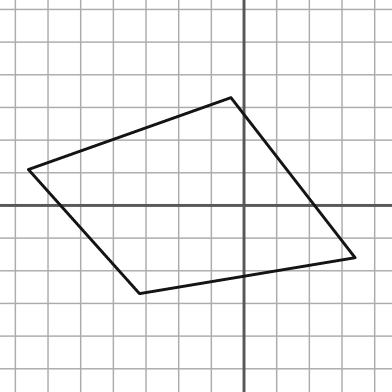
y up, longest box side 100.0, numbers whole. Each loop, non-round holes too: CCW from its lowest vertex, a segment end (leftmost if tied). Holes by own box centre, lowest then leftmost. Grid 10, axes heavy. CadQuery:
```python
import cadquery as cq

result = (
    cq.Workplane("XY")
    .moveTo(-32.0, -27.0)
    .lineTo(34.0, -16.0)
    .lineTo(-4.0, 33.0)
    .lineTo(-66.0, 11.0)
    .close()
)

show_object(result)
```